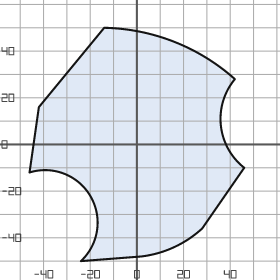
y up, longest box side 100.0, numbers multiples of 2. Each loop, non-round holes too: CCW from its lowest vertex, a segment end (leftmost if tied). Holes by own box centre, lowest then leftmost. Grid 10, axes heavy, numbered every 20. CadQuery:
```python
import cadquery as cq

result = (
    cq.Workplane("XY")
    .moveTo(-24.0, -50.0)
    .lineTo(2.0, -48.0)
    .threePointArc((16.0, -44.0), (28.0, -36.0))
    .lineTo(46.0, -10.0)
    .threePointArc((36.0, 8.0), (42.0, 28.0))
    .threePointArc((16.0, 44.0), (-14.0, 50.0))
    .lineTo(-42.0, 16.0)
    .lineTo(-46.0, -12.0)
    .threePointArc((-20.0, -22.0), (-24.0, -50.0))
    .close()
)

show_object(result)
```